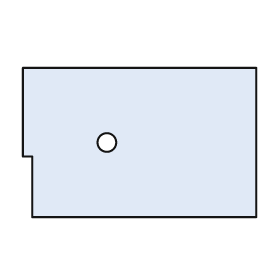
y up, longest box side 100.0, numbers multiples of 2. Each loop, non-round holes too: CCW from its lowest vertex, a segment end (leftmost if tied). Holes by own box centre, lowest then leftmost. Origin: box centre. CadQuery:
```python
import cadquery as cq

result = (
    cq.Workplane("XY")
    .moveTo(-46.0, -32.0)
    .lineTo(50.0, -32.0)
    .lineTo(50.0, 32.0)
    .lineTo(-50.0, 32.0)
    .lineTo(-50.0, -6.0)
    .lineTo(-46.0, -6.0)
    .close()
    .moveTo(-14.0, 0.0)
    .circle(4.0)
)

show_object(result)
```